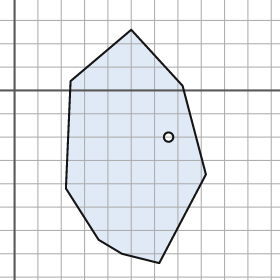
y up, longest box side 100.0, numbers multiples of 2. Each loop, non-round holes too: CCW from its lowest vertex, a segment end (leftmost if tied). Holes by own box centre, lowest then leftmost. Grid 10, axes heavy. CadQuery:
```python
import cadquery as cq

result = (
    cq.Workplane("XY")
    .moveTo(62.0, -74.0)
    .lineTo(82.0, -36.0)
    .lineTo(72.0, 2.0)
    .lineTo(50.0, 26.0)
    .lineTo(24.0, 4.0)
    .lineTo(22.0, -42.0)
    .lineTo(36.0, -64.0)
    .lineTo(46.0, -70.0)
    .close()
    .moveTo(66.0, -20.0)
    .circle(2.0)
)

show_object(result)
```